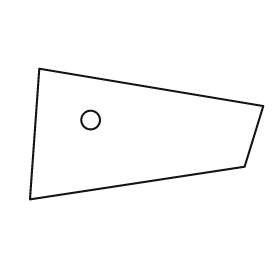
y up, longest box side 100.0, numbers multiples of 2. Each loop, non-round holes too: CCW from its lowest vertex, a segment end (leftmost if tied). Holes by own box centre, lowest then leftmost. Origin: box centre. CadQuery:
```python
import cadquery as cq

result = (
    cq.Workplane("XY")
    .moveTo(-50.0, -28.0)
    .lineTo(42.0, -14.0)
    .lineTo(50.0, 12.0)
    .lineTo(-46.0, 28.0)
    .close()
    .moveTo(-24.0, 6.0)
    .circle(4.0)
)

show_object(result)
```